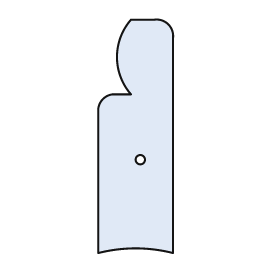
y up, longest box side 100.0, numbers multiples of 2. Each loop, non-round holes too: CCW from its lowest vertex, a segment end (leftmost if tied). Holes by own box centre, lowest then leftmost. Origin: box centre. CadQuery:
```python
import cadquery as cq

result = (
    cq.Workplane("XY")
    .moveTo(-16.0, -50.0)
    .threePointArc((0.0, -48.0), (16.0, -50.0))
    .lineTo(16.0, 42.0)
    .threePointArc((14.0, 48.0), (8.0, 50.0))
    .lineTo(-2.0, 50.0)
    .threePointArc((-8.0, 34.0), (-2.0, 18.0))
    .lineTo(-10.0, 18.0)
    .threePointArc((-14.0, 16.0), (-16.0, 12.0))
    .close()
    .moveTo(2.0, -10.0)
    .circle(2.0)
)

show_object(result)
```